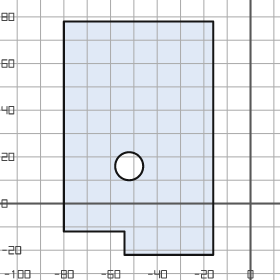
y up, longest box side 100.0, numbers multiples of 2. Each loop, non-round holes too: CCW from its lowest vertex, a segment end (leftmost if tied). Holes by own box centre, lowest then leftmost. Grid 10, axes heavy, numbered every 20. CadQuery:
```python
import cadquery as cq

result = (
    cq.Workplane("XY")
    .moveTo(-54.0, -22.0)
    .lineTo(-16.0, -22.0)
    .lineTo(-16.0, 78.0)
    .lineTo(-80.0, 78.0)
    .lineTo(-80.0, -12.0)
    .lineTo(-54.0, -12.0)
    .close()
    .moveTo(-52.0, 16.0)
    .circle(6.0)
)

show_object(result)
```